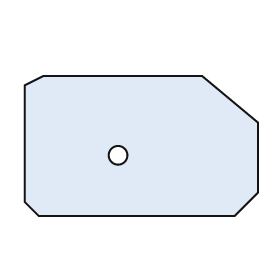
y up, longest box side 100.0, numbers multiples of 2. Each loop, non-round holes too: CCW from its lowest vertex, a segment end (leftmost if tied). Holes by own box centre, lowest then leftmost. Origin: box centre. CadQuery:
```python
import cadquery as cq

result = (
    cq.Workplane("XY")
    .moveTo(-44.0, -30.0)
    .lineTo(40.0, -30.0)
    .lineTo(50.0, -20.0)
    .lineTo(50.0, 10.0)
    .lineTo(26.0, 30.0)
    .lineTo(-42.0, 30.0)
    .lineTo(-50.0, 26.0)
    .lineTo(-50.0, -24.0)
    .close()
    .moveTo(-10.0, -4.0)
    .circle(4.0)
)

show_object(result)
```